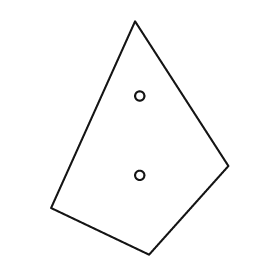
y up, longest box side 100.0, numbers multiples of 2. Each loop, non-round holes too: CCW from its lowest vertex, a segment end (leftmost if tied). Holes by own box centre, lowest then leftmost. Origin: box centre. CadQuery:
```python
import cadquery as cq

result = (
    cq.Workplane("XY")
    .moveTo(4.0, -50.0)
    .lineTo(38.0, -12.0)
    .lineTo(-2.0, 50.0)
    .lineTo(-38.0, -30.0)
    .close()
    .moveTo(0.0, -16.0)
    .circle(2.0)
    .moveTo(0.0, 18.0)
    .circle(2.0)
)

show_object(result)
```